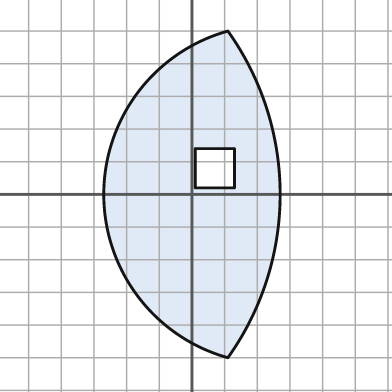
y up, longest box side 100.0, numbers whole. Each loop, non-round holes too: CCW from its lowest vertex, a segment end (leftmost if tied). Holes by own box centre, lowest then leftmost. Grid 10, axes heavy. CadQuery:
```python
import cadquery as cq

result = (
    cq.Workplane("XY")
    .moveTo(11.0, -50.0)
    .threePointArc((27.0, 0.0), (11.0, 50.0))
    .threePointArc((-27.0, 0.0), (11.0, -50.0))
    .close()
    .moveTo(1.0, 2.0)
    .lineTo(13.0, 2.0)
    .lineTo(13.0, 14.0)
    .lineTo(1.0, 14.0)
    .close()
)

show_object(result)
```